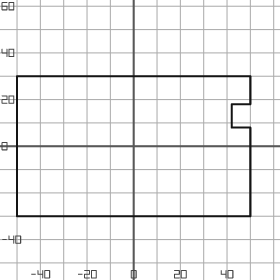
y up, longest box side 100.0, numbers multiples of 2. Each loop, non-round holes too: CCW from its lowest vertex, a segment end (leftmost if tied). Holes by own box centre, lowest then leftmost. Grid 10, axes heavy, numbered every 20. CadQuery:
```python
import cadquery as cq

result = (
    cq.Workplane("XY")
    .moveTo(-50.0, -30.0)
    .lineTo(50.0, -30.0)
    .lineTo(50.0, 8.0)
    .lineTo(42.0, 8.0)
    .lineTo(42.0, 18.0)
    .lineTo(50.0, 18.0)
    .lineTo(50.0, 30.0)
    .lineTo(-50.0, 30.0)
    .close()
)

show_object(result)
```